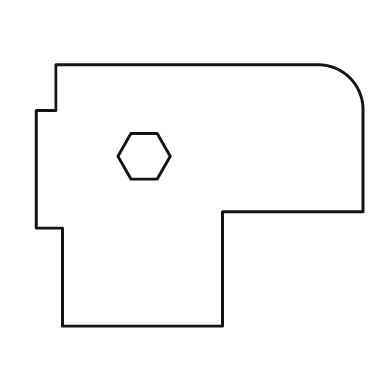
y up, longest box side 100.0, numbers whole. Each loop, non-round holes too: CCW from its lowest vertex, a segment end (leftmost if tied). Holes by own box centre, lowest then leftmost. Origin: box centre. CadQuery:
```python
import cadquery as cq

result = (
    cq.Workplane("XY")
    .moveTo(-42.0, -40.0)
    .lineTo(7.0, -40.0)
    .lineTo(7.0, -5.0)
    .lineTo(50.0, -5.0)
    .lineTo(50.0, 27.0)
    .threePointArc((46.0, 36.0), (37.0, 40.0))
    .lineTo(-44.0, 40.0)
    .lineTo(-44.0, 26.0)
    .lineTo(-50.0, 26.0)
    .lineTo(-50.0, -10.0)
    .lineTo(-42.0, -10.0)
    .close()
    .moveTo(-21.0, 5.0)
    .lineTo(-13.0, 5.0)
    .lineTo(-9.0, 12.0)
    .lineTo(-13.0, 19.0)
    .lineTo(-21.0, 19.0)
    .lineTo(-25.0, 12.0)
    .close()
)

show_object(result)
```